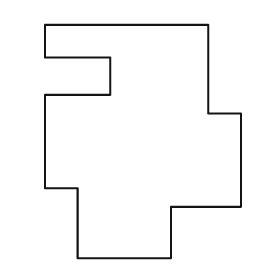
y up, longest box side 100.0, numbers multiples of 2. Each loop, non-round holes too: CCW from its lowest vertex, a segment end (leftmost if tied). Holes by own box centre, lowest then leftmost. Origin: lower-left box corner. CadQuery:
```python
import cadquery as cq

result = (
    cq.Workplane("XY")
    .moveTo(14.0, 0.0)
    .lineTo(54.0, 0.0)
    .lineTo(54.0, 22.0)
    .lineTo(84.0, 22.0)
    .lineTo(84.0, 62.0)
    .lineTo(70.0, 62.0)
    .lineTo(70.0, 100.0)
    .lineTo(0.0, 100.0)
    .lineTo(0.0, 86.0)
    .lineTo(28.0, 86.0)
    .lineTo(28.0, 70.0)
    .lineTo(0.0, 70.0)
    .lineTo(0.0, 30.0)
    .lineTo(14.0, 30.0)
    .close()
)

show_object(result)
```